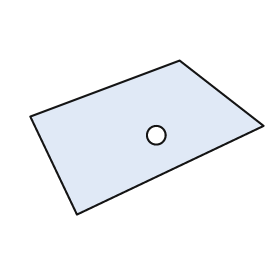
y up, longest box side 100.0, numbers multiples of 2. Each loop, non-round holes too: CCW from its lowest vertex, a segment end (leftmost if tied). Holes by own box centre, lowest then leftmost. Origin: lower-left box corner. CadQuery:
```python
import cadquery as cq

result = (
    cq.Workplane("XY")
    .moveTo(20.0, 0.0)
    .lineTo(100.0, 38.0)
    .lineTo(64.0, 66.0)
    .lineTo(0.0, 42.0)
    .close()
    .moveTo(54.0, 34.0)
    .circle(4.0)
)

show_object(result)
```